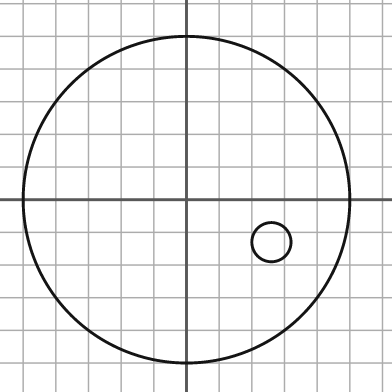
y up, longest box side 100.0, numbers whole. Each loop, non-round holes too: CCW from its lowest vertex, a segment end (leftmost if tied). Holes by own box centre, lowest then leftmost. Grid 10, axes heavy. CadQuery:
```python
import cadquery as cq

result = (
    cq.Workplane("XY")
    .moveTo(0.0, 0.0)
    .circle(50.0)
    .moveTo(26.0, -13.0)
    .circle(6.0)
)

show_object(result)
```